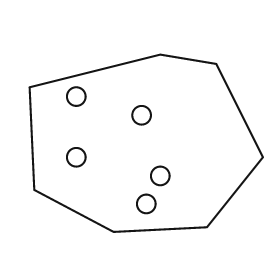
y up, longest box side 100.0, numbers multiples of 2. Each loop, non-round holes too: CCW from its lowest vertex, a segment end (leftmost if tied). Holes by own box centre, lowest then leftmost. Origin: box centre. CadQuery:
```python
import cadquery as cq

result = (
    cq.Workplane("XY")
    .moveTo(-14.0, -38.0)
    .lineTo(26.0, -36.0)
    .lineTo(50.0, -6.0)
    .lineTo(30.0, 34.0)
    .lineTo(6.0, 38.0)
    .lineTo(-50.0, 24.0)
    .lineTo(-48.0, -20.0)
    .close()
    .moveTo(0.0, -26.0)
    .circle(4.0)
    .moveTo(6.0, -14.0)
    .circle(4.0)
    .moveTo(-30.0, -6.0)
    .circle(4.0)
    .moveTo(-2.0, 12.0)
    .circle(4.0)
    .moveTo(-30.0, 20.0)
    .circle(4.0)
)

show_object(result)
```